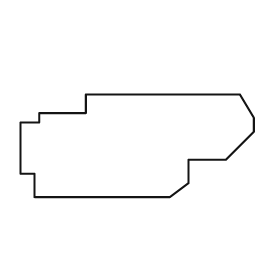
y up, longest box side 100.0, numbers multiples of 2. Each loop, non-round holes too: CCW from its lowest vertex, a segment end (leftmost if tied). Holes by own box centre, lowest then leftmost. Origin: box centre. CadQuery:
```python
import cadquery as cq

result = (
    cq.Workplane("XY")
    .moveTo(-44.0, -22.0)
    .lineTo(14.0, -22.0)
    .lineTo(22.0, -16.0)
    .lineTo(22.0, -6.0)
    .lineTo(38.0, -6.0)
    .lineTo(50.0, 6.0)
    .lineTo(50.0, 12.0)
    .lineTo(44.0, 22.0)
    .lineTo(-22.0, 22.0)
    .lineTo(-22.0, 14.0)
    .lineTo(-42.0, 14.0)
    .lineTo(-42.0, 10.0)
    .lineTo(-50.0, 10.0)
    .lineTo(-50.0, -12.0)
    .lineTo(-44.0, -12.0)
    .close()
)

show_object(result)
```